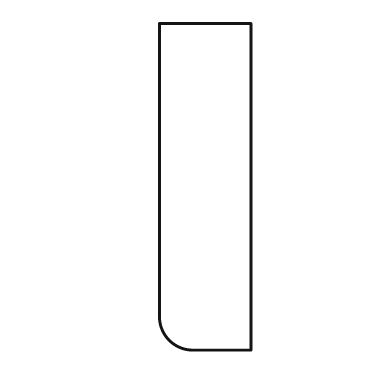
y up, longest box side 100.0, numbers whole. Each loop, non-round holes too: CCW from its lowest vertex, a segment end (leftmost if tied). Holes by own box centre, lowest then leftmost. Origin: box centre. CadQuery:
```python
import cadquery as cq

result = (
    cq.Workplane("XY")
    .moveTo(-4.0, -50.0)
    .lineTo(14.0, -50.0)
    .lineTo(14.0, 50.0)
    .lineTo(-14.0, 50.0)
    .lineTo(-14.0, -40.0)
    .threePointArc((-11.0, -47.0), (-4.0, -50.0))
    .close()
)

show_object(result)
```